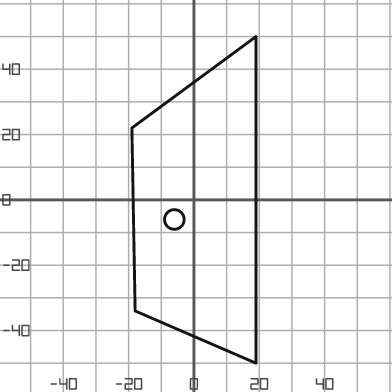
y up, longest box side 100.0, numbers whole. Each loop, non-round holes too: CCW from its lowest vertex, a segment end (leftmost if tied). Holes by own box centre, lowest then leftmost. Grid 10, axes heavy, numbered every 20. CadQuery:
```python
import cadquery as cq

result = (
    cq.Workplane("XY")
    .moveTo(19.0, -50.0)
    .lineTo(19.0, 50.0)
    .lineTo(-19.0, 22.0)
    .lineTo(-18.0, -34.0)
    .close()
    .moveTo(-6.0, -6.0)
    .circle(3.0)
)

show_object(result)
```